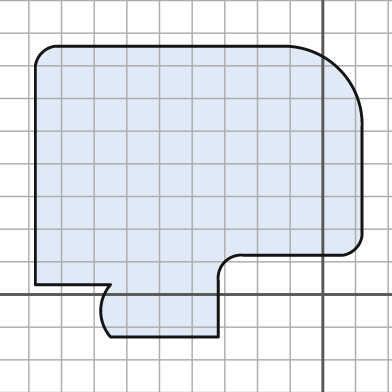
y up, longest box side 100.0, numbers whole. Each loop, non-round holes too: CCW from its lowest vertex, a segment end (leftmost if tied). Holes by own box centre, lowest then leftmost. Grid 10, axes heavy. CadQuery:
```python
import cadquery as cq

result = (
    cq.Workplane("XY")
    .moveTo(-65.0, -13.0)
    .lineTo(-32.0, -13.0)
    .lineTo(-32.0, 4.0)
    .threePointArc((-30.0, 10.0), (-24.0, 12.0))
    .lineTo(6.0, 12.0)
    .threePointArc((10.0, 14.0), (12.0, 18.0))
    .lineTo(12.0, 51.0)
    .threePointArc((5.0, 69.0), (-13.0, 76.0))
    .lineTo(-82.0, 76.0)
    .threePointArc((-86.0, 74.0), (-88.0, 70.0))
    .lineTo(-88.0, 3.0)
    .lineTo(-65.0, 3.0)
    .threePointArc((-68.0, -5.0), (-65.0, -13.0))
    .close()
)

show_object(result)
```